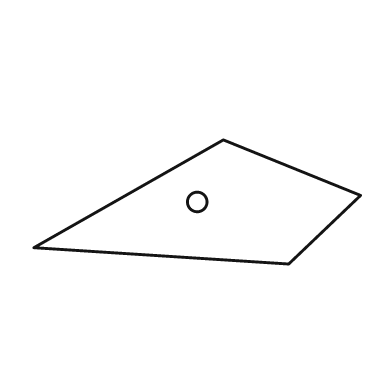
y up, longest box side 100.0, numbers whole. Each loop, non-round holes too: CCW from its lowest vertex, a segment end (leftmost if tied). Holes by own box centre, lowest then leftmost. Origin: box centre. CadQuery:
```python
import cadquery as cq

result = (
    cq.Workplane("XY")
    .moveTo(28.0, -19.0)
    .lineTo(50.0, 2.0)
    .lineTo(8.0, 19.0)
    .lineTo(-50.0, -14.0)
    .close()
    .moveTo(0.0, 0.0)
    .circle(3.0)
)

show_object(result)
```